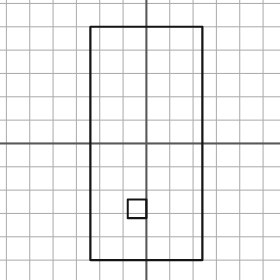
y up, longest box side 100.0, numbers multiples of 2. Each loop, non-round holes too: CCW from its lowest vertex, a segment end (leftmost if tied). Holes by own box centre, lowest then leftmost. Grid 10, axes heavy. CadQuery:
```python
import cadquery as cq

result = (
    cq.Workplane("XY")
    .moveTo(-24.0, -50.0)
    .lineTo(24.0, -50.0)
    .lineTo(24.0, 50.0)
    .lineTo(-24.0, 50.0)
    .close()
    .moveTo(-8.0, -32.0)
    .lineTo(0.0, -32.0)
    .lineTo(0.0, -24.0)
    .lineTo(-8.0, -24.0)
    .close()
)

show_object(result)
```